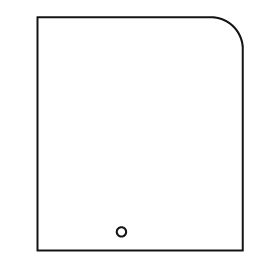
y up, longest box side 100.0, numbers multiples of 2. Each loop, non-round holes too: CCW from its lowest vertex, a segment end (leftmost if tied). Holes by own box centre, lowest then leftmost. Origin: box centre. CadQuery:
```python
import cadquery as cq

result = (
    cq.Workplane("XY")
    .moveTo(-44.0, -50.0)
    .lineTo(44.0, -50.0)
    .lineTo(44.0, 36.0)
    .threePointArc((40.0, 46.0), (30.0, 50.0))
    .lineTo(-44.0, 50.0)
    .close()
    .moveTo(-8.0, -42.0)
    .circle(2.0)
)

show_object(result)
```